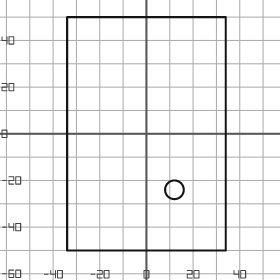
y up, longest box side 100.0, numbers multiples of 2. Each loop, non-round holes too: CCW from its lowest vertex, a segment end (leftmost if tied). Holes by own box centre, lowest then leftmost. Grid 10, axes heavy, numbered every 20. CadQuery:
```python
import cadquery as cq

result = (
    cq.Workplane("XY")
    .moveTo(-34.0, -50.0)
    .lineTo(34.0, -50.0)
    .lineTo(34.0, 50.0)
    .lineTo(-34.0, 50.0)
    .close()
    .moveTo(12.0, -24.0)
    .circle(4.0)
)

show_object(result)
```